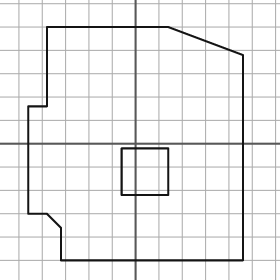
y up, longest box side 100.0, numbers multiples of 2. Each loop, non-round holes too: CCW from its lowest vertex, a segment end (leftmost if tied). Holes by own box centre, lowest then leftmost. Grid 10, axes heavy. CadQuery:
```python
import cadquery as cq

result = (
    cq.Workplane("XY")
    .moveTo(-32.0, -50.0)
    .lineTo(46.0, -50.0)
    .lineTo(46.0, 38.0)
    .lineTo(14.0, 50.0)
    .lineTo(-38.0, 50.0)
    .lineTo(-38.0, 16.0)
    .lineTo(-46.0, 16.0)
    .lineTo(-46.0, -30.0)
    .lineTo(-38.0, -30.0)
    .lineTo(-32.0, -36.0)
    .close()
    .moveTo(-6.0, -22.0)
    .lineTo(14.0, -22.0)
    .lineTo(14.0, -2.0)
    .lineTo(-6.0, -2.0)
    .close()
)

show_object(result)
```